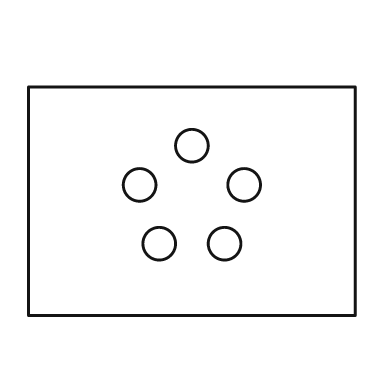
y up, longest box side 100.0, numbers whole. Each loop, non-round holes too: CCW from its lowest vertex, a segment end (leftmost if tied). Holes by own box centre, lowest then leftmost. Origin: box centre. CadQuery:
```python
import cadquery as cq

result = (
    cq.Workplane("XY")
    .moveTo(-50.0, -35.0)
    .lineTo(50.0, -35.0)
    .lineTo(50.0, 35.0)
    .lineTo(-50.0, 35.0)
    .close()
    .moveTo(-10.0, -13.0)
    .circle(5.0)
    .moveTo(10.0, -13.0)
    .circle(5.0)
    .moveTo(-16.0, 5.0)
    .circle(5.0)
    .moveTo(16.0, 5.0)
    .circle(5.0)
    .moveTo(0.0, 17.0)
    .circle(5.0)
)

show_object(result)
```